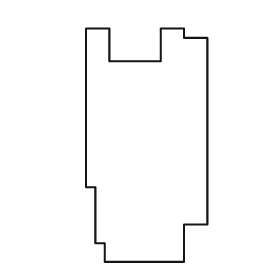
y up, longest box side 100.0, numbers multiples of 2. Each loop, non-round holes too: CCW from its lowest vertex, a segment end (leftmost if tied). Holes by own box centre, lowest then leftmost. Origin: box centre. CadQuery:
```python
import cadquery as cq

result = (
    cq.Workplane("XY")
    .moveTo(-18.0, -50.0)
    .lineTo(16.0, -50.0)
    .lineTo(16.0, -34.0)
    .lineTo(26.0, -34.0)
    .lineTo(26.0, 46.0)
    .lineTo(16.0, 46.0)
    .lineTo(16.0, 50.0)
    .lineTo(6.0, 50.0)
    .lineTo(6.0, 36.0)
    .lineTo(-16.0, 36.0)
    .lineTo(-16.0, 50.0)
    .lineTo(-26.0, 50.0)
    .lineTo(-26.0, -18.0)
    .lineTo(-22.0, -18.0)
    .lineTo(-22.0, -42.0)
    .lineTo(-18.0, -42.0)
    .close()
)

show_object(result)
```